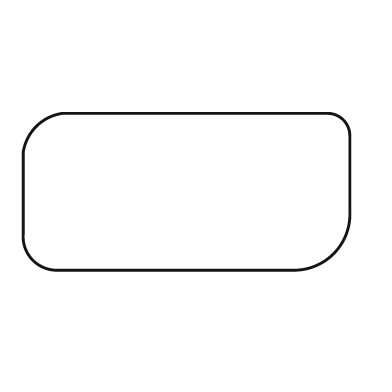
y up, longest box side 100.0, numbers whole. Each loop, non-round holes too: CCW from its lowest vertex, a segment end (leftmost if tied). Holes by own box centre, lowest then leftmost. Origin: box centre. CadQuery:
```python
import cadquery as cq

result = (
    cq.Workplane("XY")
    .moveTo(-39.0, -24.0)
    .lineTo(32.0, -24.0)
    .threePointArc((45.0, -19.0), (50.0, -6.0))
    .lineTo(50.0, 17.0)
    .threePointArc((48.0, 22.0), (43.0, 24.0))
    .lineTo(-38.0, 24.0)
    .threePointArc((-46.0, 20.0), (-50.0, 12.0))
    .lineTo(-50.0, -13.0)
    .threePointArc((-47.0, -21.0), (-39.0, -24.0))
    .close()
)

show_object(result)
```